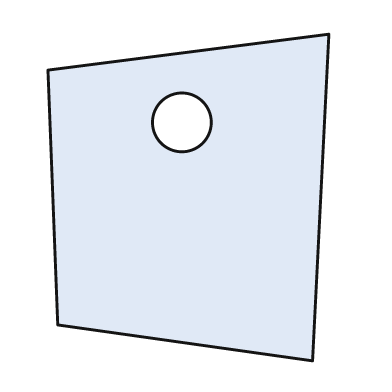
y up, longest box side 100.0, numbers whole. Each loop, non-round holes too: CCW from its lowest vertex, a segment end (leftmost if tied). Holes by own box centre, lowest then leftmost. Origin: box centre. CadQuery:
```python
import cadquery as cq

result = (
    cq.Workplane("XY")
    .moveTo(38.0, -50.0)
    .lineTo(43.0, 50.0)
    .lineTo(-43.0, 39.0)
    .lineTo(-40.0, -39.0)
    .close()
    .moveTo(-2.0, 23.0)
    .circle(9.0)
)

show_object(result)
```